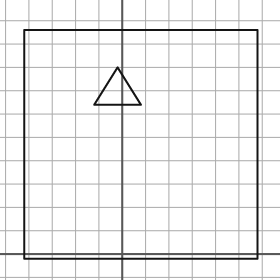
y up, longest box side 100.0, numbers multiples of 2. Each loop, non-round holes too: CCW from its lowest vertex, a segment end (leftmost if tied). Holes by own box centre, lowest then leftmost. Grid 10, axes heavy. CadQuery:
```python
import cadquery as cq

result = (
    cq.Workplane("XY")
    .moveTo(-42.0, -2.0)
    .lineTo(58.0, -2.0)
    .lineTo(58.0, 96.0)
    .lineTo(-42.0, 96.0)
    .close()
    .moveTo(-12.0, 64.0)
    .lineTo(8.0, 64.0)
    .lineTo(-2.0, 80.0)
    .close()
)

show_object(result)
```